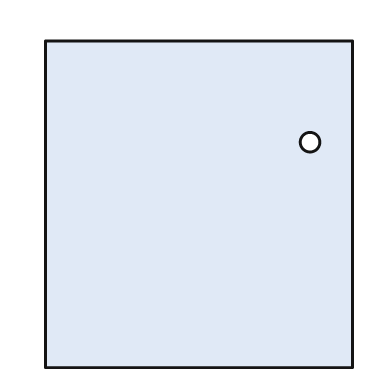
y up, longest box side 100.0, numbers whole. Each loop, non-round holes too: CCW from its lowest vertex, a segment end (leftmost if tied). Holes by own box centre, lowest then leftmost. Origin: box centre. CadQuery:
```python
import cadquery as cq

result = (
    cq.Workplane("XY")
    .moveTo(-47.0, -50.0)
    .lineTo(47.0, -50.0)
    .lineTo(47.0, 50.0)
    .lineTo(-47.0, 50.0)
    .close()
    .moveTo(34.0, 19.0)
    .circle(3.0)
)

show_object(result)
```